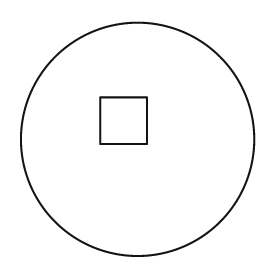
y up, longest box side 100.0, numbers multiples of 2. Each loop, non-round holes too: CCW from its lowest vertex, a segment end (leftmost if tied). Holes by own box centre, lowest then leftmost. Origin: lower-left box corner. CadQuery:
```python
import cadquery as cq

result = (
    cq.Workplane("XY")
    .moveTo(50.0, 50.0)
    .circle(50.0)
    .moveTo(34.0, 48.0)
    .lineTo(54.0, 48.0)
    .lineTo(54.0, 68.0)
    .lineTo(34.0, 68.0)
    .close()
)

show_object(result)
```